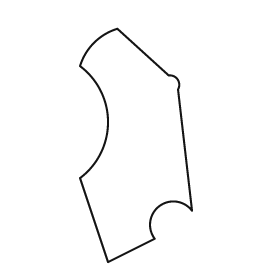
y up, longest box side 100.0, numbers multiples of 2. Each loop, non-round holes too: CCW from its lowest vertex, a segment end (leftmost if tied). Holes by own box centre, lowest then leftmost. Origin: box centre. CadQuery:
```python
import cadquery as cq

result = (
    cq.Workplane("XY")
    .moveTo(-12.0, -50.0)
    .lineTo(8.0, -40.0)
    .threePointArc((10.0, -26.0), (24.0, -28.0))
    .lineTo(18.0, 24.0)
    .threePointArc((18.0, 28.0), (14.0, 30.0))
    .lineTo(-8.0, 50.0)
    .threePointArc((-18.0, 44.0), (-24.0, 34.0))
    .threePointArc((-12.0, 10.0), (-24.0, -14.0))
    .close()
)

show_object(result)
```